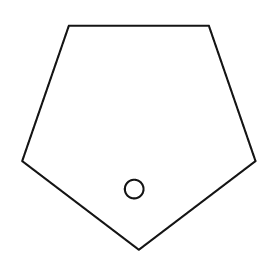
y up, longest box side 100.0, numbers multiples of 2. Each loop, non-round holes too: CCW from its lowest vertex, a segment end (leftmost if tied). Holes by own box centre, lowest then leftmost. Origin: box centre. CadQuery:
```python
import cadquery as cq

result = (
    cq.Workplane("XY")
    .moveTo(0.0, -48.0)
    .lineTo(50.0, -10.0)
    .lineTo(30.0, 48.0)
    .lineTo(-30.0, 48.0)
    .lineTo(-50.0, -10.0)
    .close()
    .moveTo(-2.0, -22.0)
    .circle(4.0)
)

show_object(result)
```